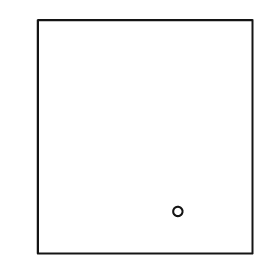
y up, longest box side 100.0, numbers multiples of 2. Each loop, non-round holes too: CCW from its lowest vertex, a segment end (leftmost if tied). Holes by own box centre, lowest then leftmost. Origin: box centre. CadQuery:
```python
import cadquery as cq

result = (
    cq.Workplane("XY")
    .moveTo(-46.0, -50.0)
    .lineTo(46.0, -50.0)
    .lineTo(46.0, 50.0)
    .lineTo(-46.0, 50.0)
    .close()
    .moveTo(14.0, -32.0)
    .circle(2.0)
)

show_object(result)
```